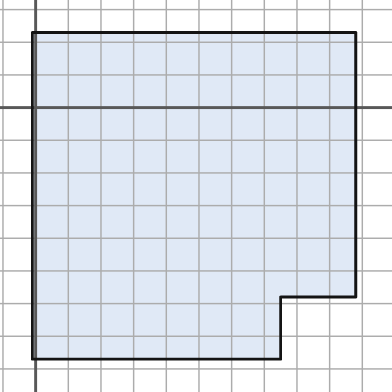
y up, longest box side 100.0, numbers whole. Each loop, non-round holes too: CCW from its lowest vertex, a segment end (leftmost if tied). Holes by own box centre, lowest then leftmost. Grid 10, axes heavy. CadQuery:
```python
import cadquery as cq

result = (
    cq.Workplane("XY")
    .moveTo(-1.0, -77.0)
    .lineTo(75.0, -77.0)
    .lineTo(75.0, -58.0)
    .lineTo(98.0, -58.0)
    .lineTo(98.0, 23.0)
    .lineTo(-1.0, 23.0)
    .close()
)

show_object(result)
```